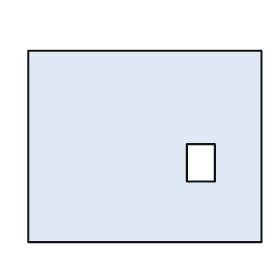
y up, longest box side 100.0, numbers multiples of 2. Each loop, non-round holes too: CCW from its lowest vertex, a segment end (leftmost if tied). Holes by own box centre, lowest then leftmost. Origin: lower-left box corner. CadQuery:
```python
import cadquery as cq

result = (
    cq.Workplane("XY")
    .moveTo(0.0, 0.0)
    .lineTo(100.0, 0.0)
    .lineTo(100.0, 82.0)
    .lineTo(0.0, 82.0)
    .close()
    .moveTo(68.0, 26.0)
    .lineTo(80.0, 26.0)
    .lineTo(80.0, 42.0)
    .lineTo(68.0, 42.0)
    .close()
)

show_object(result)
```